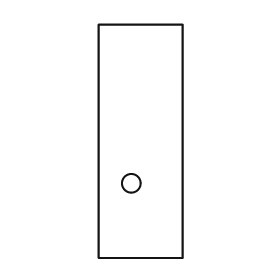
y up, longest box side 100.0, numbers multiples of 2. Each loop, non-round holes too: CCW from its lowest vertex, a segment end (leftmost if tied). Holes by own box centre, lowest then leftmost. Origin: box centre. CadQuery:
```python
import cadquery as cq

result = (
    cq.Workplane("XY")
    .moveTo(-18.0, -50.0)
    .lineTo(18.0, -50.0)
    .lineTo(18.0, 50.0)
    .lineTo(-18.0, 50.0)
    .close()
    .moveTo(-4.0, -18.0)
    .circle(4.0)
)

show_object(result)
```